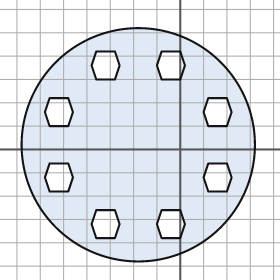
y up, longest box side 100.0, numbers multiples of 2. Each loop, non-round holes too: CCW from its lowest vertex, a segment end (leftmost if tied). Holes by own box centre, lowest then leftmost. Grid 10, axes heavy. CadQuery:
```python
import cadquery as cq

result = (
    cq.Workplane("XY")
    .moveTo(-18.0, 2.0)
    .circle(50.0)
    .moveTo(-36.0, -38.0)
    .lineTo(-28.0, -38.0)
    .lineTo(-26.0, -32.0)
    .lineTo(-28.0, -26.0)
    .lineTo(-36.0, -26.0)
    .lineTo(-38.0, -32.0)
    .close()
    .moveTo(-8.0, -38.0)
    .lineTo(0.0, -38.0)
    .lineTo(2.0, -32.0)
    .lineTo(0.0, -26.0)
    .lineTo(-8.0, -26.0)
    .lineTo(-10.0, -32.0)
    .close()
    .moveTo(-56.0, -18.0)
    .lineTo(-48.0, -18.0)
    .lineTo(-46.0, -12.0)
    .lineTo(-48.0, -6.0)
    .lineTo(-56.0, -6.0)
    .lineTo(-58.0, -12.0)
    .close()
    .moveTo(12.0, -18.0)
    .lineTo(20.0, -18.0)
    .lineTo(22.0, -12.0)
    .lineTo(20.0, -6.0)
    .lineTo(12.0, -6.0)
    .lineTo(10.0, -12.0)
    .close()
    .moveTo(-56.0, 10.0)
    .lineTo(-48.0, 10.0)
    .lineTo(-46.0, 16.0)
    .lineTo(-48.0, 22.0)
    .lineTo(-56.0, 22.0)
    .lineTo(-58.0, 16.0)
    .close()
    .moveTo(12.0, 10.0)
    .lineTo(20.0, 10.0)
    .lineTo(22.0, 16.0)
    .lineTo(20.0, 22.0)
    .lineTo(12.0, 22.0)
    .lineTo(10.0, 16.0)
    .close()
    .moveTo(-36.0, 30.0)
    .lineTo(-28.0, 30.0)
    .lineTo(-26.0, 36.0)
    .lineTo(-28.0, 42.0)
    .lineTo(-36.0, 42.0)
    .lineTo(-38.0, 36.0)
    .close()
    .moveTo(-8.0, 30.0)
    .lineTo(0.0, 30.0)
    .lineTo(2.0, 36.0)
    .lineTo(0.0, 42.0)
    .lineTo(-8.0, 42.0)
    .lineTo(-10.0, 36.0)
    .close()
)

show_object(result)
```